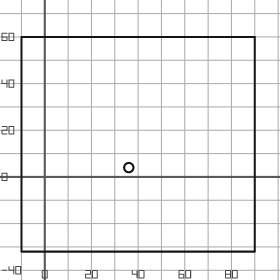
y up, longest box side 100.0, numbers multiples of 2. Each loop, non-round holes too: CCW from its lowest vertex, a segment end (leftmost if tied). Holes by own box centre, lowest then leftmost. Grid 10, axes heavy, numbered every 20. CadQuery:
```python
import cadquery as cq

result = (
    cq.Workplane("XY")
    .moveTo(-10.0, -32.0)
    .lineTo(90.0, -32.0)
    .lineTo(90.0, 60.0)
    .lineTo(-10.0, 60.0)
    .close()
    .moveTo(36.0, 4.0)
    .circle(2.0)
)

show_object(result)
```